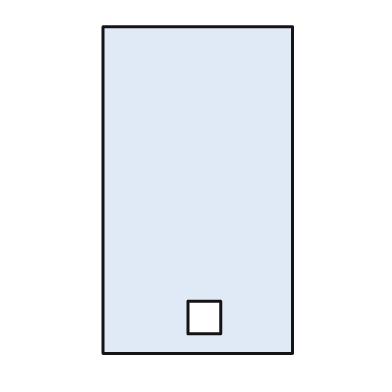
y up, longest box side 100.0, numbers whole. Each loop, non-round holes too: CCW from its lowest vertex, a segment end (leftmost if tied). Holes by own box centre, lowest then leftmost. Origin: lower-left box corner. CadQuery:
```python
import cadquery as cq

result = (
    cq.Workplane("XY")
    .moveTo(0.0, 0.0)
    .lineTo(58.0, 0.0)
    .lineTo(58.0, 100.0)
    .lineTo(0.0, 100.0)
    .close()
    .moveTo(26.0, 6.0)
    .lineTo(36.0, 6.0)
    .lineTo(36.0, 16.0)
    .lineTo(26.0, 16.0)
    .close()
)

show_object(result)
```